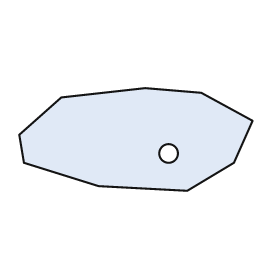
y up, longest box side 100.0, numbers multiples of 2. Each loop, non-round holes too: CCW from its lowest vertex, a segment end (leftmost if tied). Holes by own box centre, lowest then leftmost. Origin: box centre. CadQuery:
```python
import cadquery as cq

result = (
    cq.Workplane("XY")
    .moveTo(22.0, -22.0)
    .lineTo(42.0, -10.0)
    .lineTo(50.0, 8.0)
    .lineTo(28.0, 20.0)
    .lineTo(4.0, 22.0)
    .lineTo(-32.0, 18.0)
    .lineTo(-50.0, 2.0)
    .lineTo(-48.0, -10.0)
    .lineTo(-16.0, -20.0)
    .close()
    .moveTo(14.0, -6.0)
    .circle(4.0)
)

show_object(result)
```